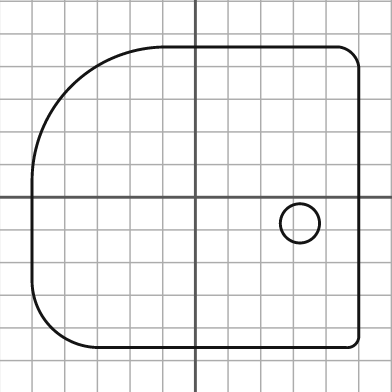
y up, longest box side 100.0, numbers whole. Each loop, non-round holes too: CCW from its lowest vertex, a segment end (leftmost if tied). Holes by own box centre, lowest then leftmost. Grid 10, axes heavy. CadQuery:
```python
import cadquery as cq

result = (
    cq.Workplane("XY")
    .moveTo(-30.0, -46.0)
    .lineTo(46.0, -46.0)
    .threePointArc((49.0, -45.0), (50.0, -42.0))
    .lineTo(50.0, 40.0)
    .threePointArc((48.0, 44.0), (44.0, 46.0))
    .lineTo(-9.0, 46.0)
    .threePointArc((-38.0, 34.0), (-50.0, 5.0))
    .lineTo(-50.0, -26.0)
    .threePointArc((-44.0, -40.0), (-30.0, -46.0))
    .close()
    .moveTo(32.0, -8.0)
    .circle(6.0)
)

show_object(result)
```